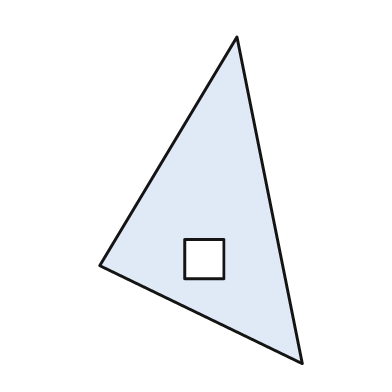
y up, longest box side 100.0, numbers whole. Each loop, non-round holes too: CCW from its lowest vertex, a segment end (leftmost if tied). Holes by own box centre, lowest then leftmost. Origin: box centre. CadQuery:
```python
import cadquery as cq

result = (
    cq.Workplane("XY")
    .moveTo(31.0, -50.0)
    .lineTo(11.0, 50.0)
    .lineTo(-31.0, -20.0)
    .close()
    .moveTo(-5.0, -24.0)
    .lineTo(7.0, -24.0)
    .lineTo(7.0, -12.0)
    .lineTo(-5.0, -12.0)
    .close()
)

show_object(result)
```